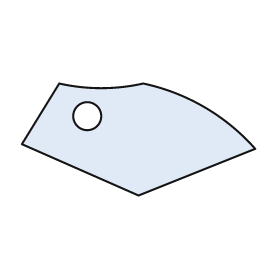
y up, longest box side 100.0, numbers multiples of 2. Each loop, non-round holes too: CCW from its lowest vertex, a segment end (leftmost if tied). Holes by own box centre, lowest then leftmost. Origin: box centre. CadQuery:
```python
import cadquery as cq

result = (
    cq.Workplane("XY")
    .moveTo(0.0, -24.0)
    .lineTo(50.0, -4.0)
    .threePointArc((28.0, 14.0), (2.0, 24.0))
    .threePointArc((-16.0, 22.0), (-34.0, 24.0))
    .lineTo(-50.0, -2.0)
    .close()
    .moveTo(-22.0, 10.0)
    .circle(6.0)
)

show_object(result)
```